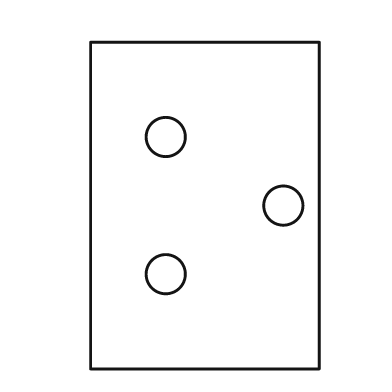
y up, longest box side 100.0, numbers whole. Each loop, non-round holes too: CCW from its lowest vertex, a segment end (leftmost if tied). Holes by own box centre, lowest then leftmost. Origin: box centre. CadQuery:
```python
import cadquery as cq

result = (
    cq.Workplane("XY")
    .moveTo(-35.0, -50.0)
    .lineTo(35.0, -50.0)
    .lineTo(35.0, 50.0)
    .lineTo(-35.0, 50.0)
    .close()
    .moveTo(-12.0, -21.0)
    .circle(6.0)
    .moveTo(24.0, 0.0)
    .circle(6.0)
    .moveTo(-12.0, 21.0)
    .circle(6.0)
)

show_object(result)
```